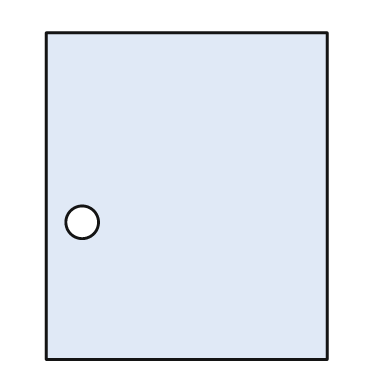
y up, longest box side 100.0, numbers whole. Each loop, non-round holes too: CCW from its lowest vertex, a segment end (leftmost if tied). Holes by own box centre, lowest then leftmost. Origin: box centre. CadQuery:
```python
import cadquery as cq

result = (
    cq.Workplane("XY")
    .moveTo(-43.0, -50.0)
    .lineTo(43.0, -50.0)
    .lineTo(43.0, 50.0)
    .lineTo(-43.0, 50.0)
    .close()
    .moveTo(-32.0, -8.0)
    .circle(5.0)
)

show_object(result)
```